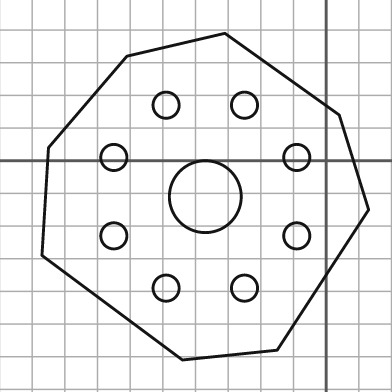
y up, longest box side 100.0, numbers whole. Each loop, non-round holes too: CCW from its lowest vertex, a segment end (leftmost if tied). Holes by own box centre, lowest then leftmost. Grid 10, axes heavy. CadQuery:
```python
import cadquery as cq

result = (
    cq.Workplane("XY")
    .moveTo(-44.0, -61.0)
    .lineTo(-15.0, -58.0)
    .lineTo(13.0, -15.0)
    .lineTo(4.0, 14.0)
    .lineTo(-31.0, 39.0)
    .lineTo(-61.0, 32.0)
    .lineTo(-85.0, 4.0)
    .lineTo(-87.0, -29.0)
    .close()
    .moveTo(-49.0, -39.0)
    .circle(4.0)
    .moveTo(-25.0, -39.0)
    .circle(4.0)
    .moveTo(-65.0, -23.0)
    .circle(4.0)
    .moveTo(-9.0, -23.0)
    .circle(4.0)
    .moveTo(-37.0, -11.0)
    .circle(11.0)
    .moveTo(-65.0, 1.0)
    .circle(4.0)
    .moveTo(-9.0, 1.0)
    .circle(4.0)
    .moveTo(-49.0, 17.0)
    .circle(4.0)
    .moveTo(-25.0, 17.0)
    .circle(4.0)
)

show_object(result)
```